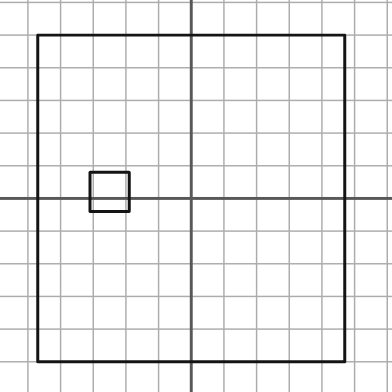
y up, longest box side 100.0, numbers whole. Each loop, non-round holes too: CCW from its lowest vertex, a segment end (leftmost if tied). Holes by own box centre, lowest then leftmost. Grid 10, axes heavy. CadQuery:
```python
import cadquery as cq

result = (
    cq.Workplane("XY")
    .moveTo(-47.0, -50.0)
    .lineTo(47.0, -50.0)
    .lineTo(47.0, 50.0)
    .lineTo(-47.0, 50.0)
    .close()
    .moveTo(-31.0, -4.0)
    .lineTo(-19.0, -4.0)
    .lineTo(-19.0, 8.0)
    .lineTo(-31.0, 8.0)
    .close()
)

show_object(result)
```